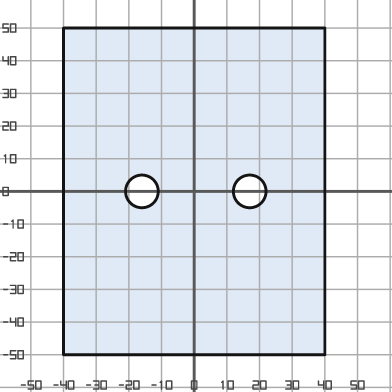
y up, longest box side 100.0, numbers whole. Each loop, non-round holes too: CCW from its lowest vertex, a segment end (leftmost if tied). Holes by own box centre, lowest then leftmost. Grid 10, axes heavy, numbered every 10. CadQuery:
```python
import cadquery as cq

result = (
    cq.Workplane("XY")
    .moveTo(-40.0, -50.0)
    .lineTo(40.0, -50.0)
    .lineTo(40.0, 50.0)
    .lineTo(-40.0, 50.0)
    .close()
    .moveTo(-16.0, 0.0)
    .circle(5.0)
    .moveTo(17.0, 0.0)
    .circle(5.0)
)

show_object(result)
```